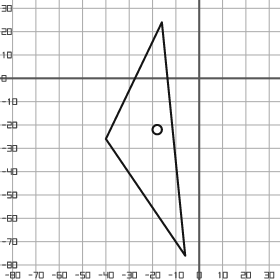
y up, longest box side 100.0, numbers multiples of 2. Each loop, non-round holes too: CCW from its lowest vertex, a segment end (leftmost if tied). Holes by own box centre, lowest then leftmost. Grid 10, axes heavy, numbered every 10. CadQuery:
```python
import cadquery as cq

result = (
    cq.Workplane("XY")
    .moveTo(-6.0, -76.0)
    .lineTo(-16.0, 24.0)
    .lineTo(-40.0, -26.0)
    .close()
    .moveTo(-18.0, -22.0)
    .circle(2.0)
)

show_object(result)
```